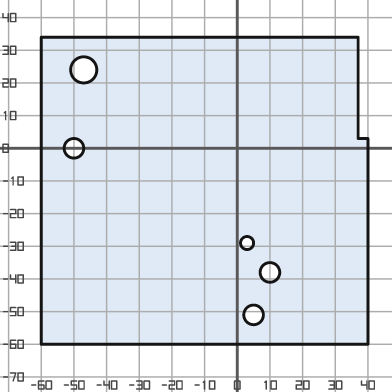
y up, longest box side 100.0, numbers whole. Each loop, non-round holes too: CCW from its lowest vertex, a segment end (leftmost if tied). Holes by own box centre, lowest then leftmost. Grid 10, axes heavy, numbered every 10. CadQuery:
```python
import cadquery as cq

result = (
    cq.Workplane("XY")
    .moveTo(-60.0, -60.0)
    .lineTo(40.0, -60.0)
    .lineTo(40.0, 3.0)
    .lineTo(37.0, 3.0)
    .lineTo(37.0, 34.0)
    .lineTo(-60.0, 34.0)
    .close()
    .moveTo(5.0, -51.0)
    .circle(3.0)
    .moveTo(10.0, -38.0)
    .circle(3.0)
    .moveTo(3.0, -29.0)
    .circle(2.0)
    .moveTo(-50.0, 0.0)
    .circle(3.0)
    .moveTo(-47.0, 24.0)
    .circle(4.0)
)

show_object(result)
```